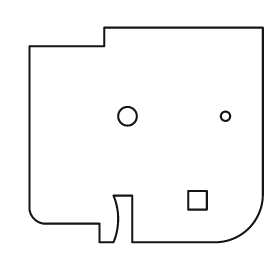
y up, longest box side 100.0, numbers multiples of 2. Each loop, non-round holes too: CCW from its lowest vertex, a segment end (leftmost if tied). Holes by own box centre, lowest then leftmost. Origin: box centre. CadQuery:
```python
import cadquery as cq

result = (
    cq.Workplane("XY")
    .moveTo(-20.0, -46.0)
    .lineTo(-14.0, -46.0)
    .threePointArc((-12.0, -36.0), (-14.0, -26.0))
    .lineTo(-6.0, -26.0)
    .lineTo(-6.0, -46.0)
    .lineTo(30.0, -46.0)
    .threePointArc((44.0, -40.0), (50.0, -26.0))
    .lineTo(50.0, 46.0)
    .lineTo(-18.0, 46.0)
    .lineTo(-18.0, 38.0)
    .lineTo(-50.0, 38.0)
    .lineTo(-50.0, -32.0)
    .threePointArc((-48.0, -36.0), (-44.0, -38.0))
    .lineTo(-20.0, -38.0)
    .close()
    .moveTo(18.0, -32.0)
    .lineTo(26.0, -32.0)
    .lineTo(26.0, -24.0)
    .lineTo(18.0, -24.0)
    .close()
    .moveTo(-8.0, 8.0)
    .circle(4.0)
    .moveTo(34.0, 8.0)
    .circle(2.0)
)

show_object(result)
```